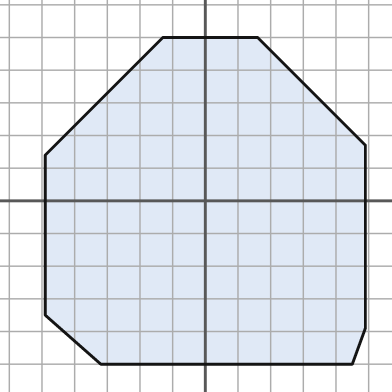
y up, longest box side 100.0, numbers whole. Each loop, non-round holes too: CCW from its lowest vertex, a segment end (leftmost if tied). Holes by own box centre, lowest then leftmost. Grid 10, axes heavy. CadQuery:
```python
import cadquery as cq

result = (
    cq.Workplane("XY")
    .moveTo(-32.0, -50.0)
    .lineTo(45.0, -50.0)
    .lineTo(49.0, -39.0)
    .lineTo(49.0, 17.0)
    .lineTo(16.0, 50.0)
    .lineTo(-13.0, 50.0)
    .lineTo(-49.0, 14.0)
    .lineTo(-49.0, -35.0)
    .close()
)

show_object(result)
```